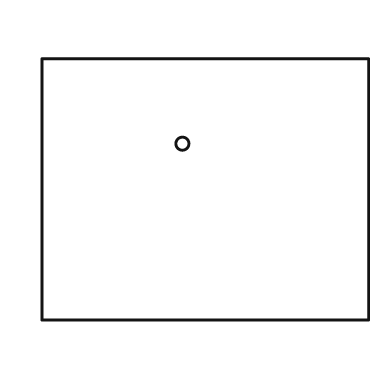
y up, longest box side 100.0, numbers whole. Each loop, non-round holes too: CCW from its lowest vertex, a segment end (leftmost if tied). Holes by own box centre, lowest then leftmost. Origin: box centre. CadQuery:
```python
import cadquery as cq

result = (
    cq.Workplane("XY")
    .moveTo(-50.0, -40.0)
    .lineTo(50.0, -40.0)
    .lineTo(50.0, 40.0)
    .lineTo(-50.0, 40.0)
    .close()
    .moveTo(-7.0, 14.0)
    .circle(2.0)
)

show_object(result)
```